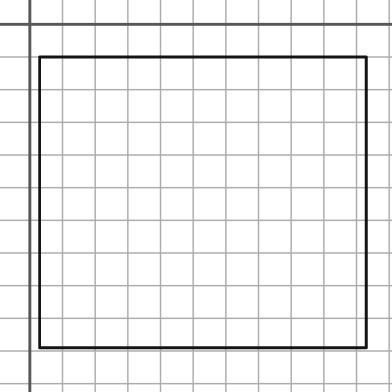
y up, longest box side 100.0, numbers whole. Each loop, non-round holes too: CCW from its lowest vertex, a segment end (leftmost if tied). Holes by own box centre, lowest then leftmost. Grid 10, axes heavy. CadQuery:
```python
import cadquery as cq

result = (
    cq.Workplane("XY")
    .moveTo(3.0, -99.0)
    .lineTo(103.0, -99.0)
    .lineTo(103.0, -10.0)
    .lineTo(3.0, -10.0)
    .close()
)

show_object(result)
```